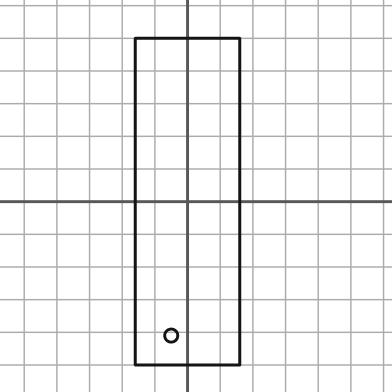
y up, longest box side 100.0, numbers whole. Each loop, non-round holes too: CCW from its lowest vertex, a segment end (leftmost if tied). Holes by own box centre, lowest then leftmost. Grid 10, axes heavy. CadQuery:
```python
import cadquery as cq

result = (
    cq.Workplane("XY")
    .moveTo(-16.0, -50.0)
    .lineTo(16.0, -50.0)
    .lineTo(16.0, 50.0)
    .lineTo(-16.0, 50.0)
    .close()
    .moveTo(-5.0, -41.0)
    .circle(2.0)
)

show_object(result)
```